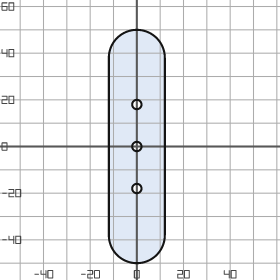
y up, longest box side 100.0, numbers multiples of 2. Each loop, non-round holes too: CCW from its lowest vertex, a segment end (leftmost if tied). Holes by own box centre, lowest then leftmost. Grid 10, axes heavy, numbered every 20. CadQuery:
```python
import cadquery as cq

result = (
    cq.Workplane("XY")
    .moveTo(-12.0, -38.0)
    .threePointArc((0.0, -50.0), (12.0, -38.0))
    .lineTo(12.0, 38.0)
    .threePointArc((0.0, 50.0), (-12.0, 38.0))
    .close()
    .moveTo(0.0, -18.0)
    .circle(2.0)
    .moveTo(0.0, 0.0)
    .circle(2.0)
    .moveTo(0.0, 18.0)
    .circle(2.0)
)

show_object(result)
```